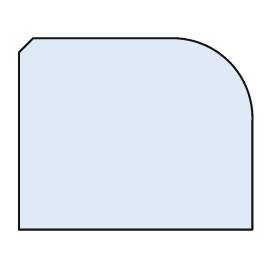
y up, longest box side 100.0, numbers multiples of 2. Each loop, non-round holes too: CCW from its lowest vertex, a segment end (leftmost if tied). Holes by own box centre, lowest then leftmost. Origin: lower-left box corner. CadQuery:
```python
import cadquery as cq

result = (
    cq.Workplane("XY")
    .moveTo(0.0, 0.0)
    .lineTo(100.0, 0.0)
    .lineTo(100.0, 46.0)
    .threePointArc((90.0, 72.0), (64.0, 82.0))
    .lineTo(6.0, 82.0)
    .lineTo(0.0, 76.0)
    .close()
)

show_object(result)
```